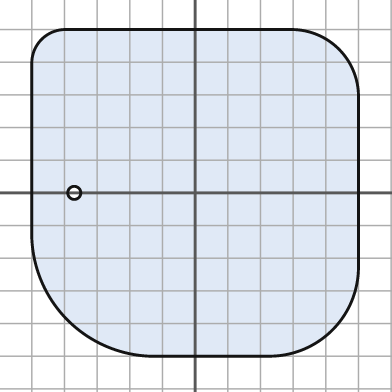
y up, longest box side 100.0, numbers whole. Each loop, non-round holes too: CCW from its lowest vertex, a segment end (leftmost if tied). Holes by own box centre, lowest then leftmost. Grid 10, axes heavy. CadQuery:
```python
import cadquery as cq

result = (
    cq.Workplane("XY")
    .moveTo(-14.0, -50.0)
    .lineTo(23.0, -50.0)
    .threePointArc((42.0, -42.0), (50.0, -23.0))
    .lineTo(50.0, 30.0)
    .threePointArc((44.0, 44.0), (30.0, 50.0))
    .lineTo(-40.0, 50.0)
    .threePointArc((-47.0, 47.0), (-50.0, 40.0))
    .lineTo(-50.0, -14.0)
    .threePointArc((-39.0, -39.0), (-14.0, -50.0))
    .close()
    .moveTo(-37.0, 0.0)
    .circle(2.0)
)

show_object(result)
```